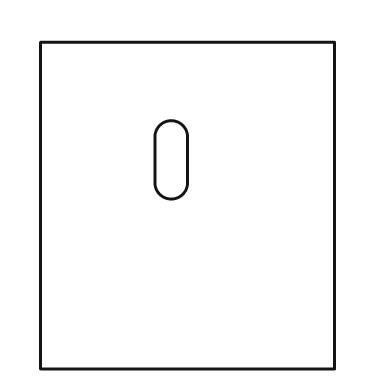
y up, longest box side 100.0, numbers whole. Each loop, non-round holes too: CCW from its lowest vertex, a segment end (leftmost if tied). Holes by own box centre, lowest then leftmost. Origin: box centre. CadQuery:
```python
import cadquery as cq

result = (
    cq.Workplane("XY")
    .moveTo(-45.0, -50.0)
    .lineTo(45.0, -50.0)
    .lineTo(45.0, 50.0)
    .lineTo(-45.0, 50.0)
    .close()
    .moveTo(-10.0, 7.0)
    .threePointArc((-5.0, 2.0), (0.0, 7.0))
    .lineTo(0.0, 21.0)
    .threePointArc((-5.0, 26.0), (-10.0, 21.0))
    .close()
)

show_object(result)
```